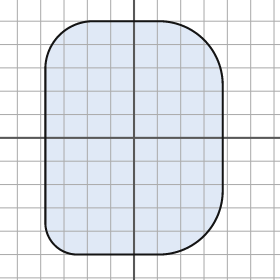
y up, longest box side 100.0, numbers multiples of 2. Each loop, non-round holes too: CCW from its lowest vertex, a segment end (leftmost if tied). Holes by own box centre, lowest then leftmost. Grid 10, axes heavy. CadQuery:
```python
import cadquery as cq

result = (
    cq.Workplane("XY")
    .moveTo(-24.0, -50.0)
    .lineTo(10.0, -50.0)
    .threePointArc((30.0, -42.0), (38.0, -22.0))
    .lineTo(38.0, 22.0)
    .threePointArc((30.0, 42.0), (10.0, 50.0))
    .lineTo(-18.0, 50.0)
    .threePointArc((-32.0, 44.0), (-38.0, 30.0))
    .lineTo(-38.0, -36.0)
    .threePointArc((-34.0, -46.0), (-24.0, -50.0))
    .close()
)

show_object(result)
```